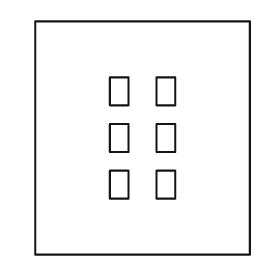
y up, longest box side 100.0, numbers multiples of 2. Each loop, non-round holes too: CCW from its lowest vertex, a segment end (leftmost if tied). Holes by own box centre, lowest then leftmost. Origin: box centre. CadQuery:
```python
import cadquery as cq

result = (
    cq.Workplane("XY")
    .moveTo(-46.0, -50.0)
    .lineTo(46.0, -50.0)
    .lineTo(46.0, 50.0)
    .lineTo(-46.0, 50.0)
    .close()
    .moveTo(-14.0, -26.0)
    .lineTo(-6.0, -26.0)
    .lineTo(-6.0, -14.0)
    .lineTo(-14.0, -14.0)
    .close()
    .moveTo(6.0, -26.0)
    .lineTo(14.0, -26.0)
    .lineTo(14.0, -14.0)
    .lineTo(6.0, -14.0)
    .close()
    .moveTo(-14.0, -6.0)
    .lineTo(-6.0, -6.0)
    .lineTo(-6.0, 6.0)
    .lineTo(-14.0, 6.0)
    .close()
    .moveTo(6.0, -6.0)
    .lineTo(14.0, -6.0)
    .lineTo(14.0, 6.0)
    .lineTo(6.0, 6.0)
    .close()
    .moveTo(-14.0, 14.0)
    .lineTo(-6.0, 14.0)
    .lineTo(-6.0, 26.0)
    .lineTo(-14.0, 26.0)
    .close()
    .moveTo(6.0, 14.0)
    .lineTo(14.0, 14.0)
    .lineTo(14.0, 26.0)
    .lineTo(6.0, 26.0)
    .close()
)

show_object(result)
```